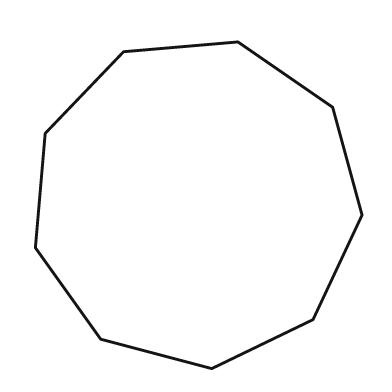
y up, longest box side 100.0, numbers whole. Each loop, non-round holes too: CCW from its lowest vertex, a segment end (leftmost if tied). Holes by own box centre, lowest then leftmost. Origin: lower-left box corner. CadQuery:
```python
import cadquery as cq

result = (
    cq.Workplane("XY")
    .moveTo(54.0, 0.0)
    .lineTo(85.0, 15.0)
    .lineTo(100.0, 47.0)
    .lineTo(91.0, 80.0)
    .lineTo(62.0, 100.0)
    .lineTo(27.0, 97.0)
    .lineTo(3.0, 72.0)
    .lineTo(0.0, 37.0)
    .lineTo(20.0, 9.0)
    .close()
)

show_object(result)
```